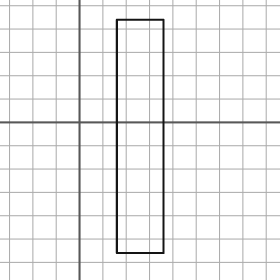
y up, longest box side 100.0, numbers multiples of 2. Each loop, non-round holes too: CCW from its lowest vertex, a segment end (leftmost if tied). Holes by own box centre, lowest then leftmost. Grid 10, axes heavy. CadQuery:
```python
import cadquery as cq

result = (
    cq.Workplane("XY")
    .moveTo(16.0, -56.0)
    .lineTo(36.0, -56.0)
    .lineTo(36.0, 44.0)
    .lineTo(16.0, 44.0)
    .close()
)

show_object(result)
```